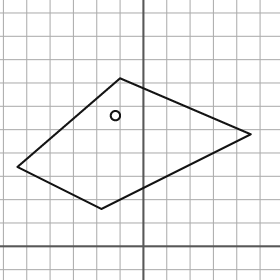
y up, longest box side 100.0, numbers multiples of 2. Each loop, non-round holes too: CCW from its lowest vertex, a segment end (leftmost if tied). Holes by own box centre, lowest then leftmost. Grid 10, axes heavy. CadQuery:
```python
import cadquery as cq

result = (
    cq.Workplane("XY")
    .moveTo(-18.0, 16.0)
    .lineTo(46.0, 48.0)
    .lineTo(-10.0, 72.0)
    .lineTo(-54.0, 34.0)
    .close()
    .moveTo(-12.0, 56.0)
    .circle(2.0)
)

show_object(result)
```